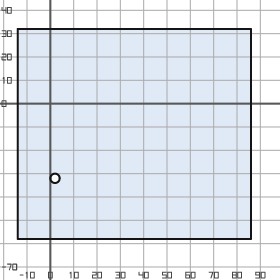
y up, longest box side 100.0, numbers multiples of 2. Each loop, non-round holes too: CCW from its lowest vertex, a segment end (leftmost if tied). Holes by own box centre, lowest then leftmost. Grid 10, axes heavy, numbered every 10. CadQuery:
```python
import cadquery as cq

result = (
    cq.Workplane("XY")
    .moveTo(-14.0, -58.0)
    .lineTo(86.0, -58.0)
    .lineTo(86.0, 32.0)
    .lineTo(-14.0, 32.0)
    .close()
    .moveTo(2.0, -32.0)
    .circle(2.0)
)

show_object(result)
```